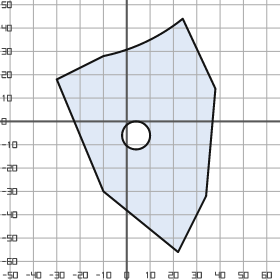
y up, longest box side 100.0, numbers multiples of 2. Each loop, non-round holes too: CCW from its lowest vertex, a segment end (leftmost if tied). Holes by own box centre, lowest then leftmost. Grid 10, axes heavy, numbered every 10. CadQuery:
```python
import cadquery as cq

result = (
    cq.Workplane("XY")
    .moveTo(22.0, -56.0)
    .lineTo(34.0, -32.0)
    .lineTo(38.0, 14.0)
    .lineTo(24.0, 44.0)
    .threePointArc((8.0, 34.0), (-10.0, 28.0))
    .lineTo(-30.0, 18.0)
    .lineTo(-10.0, -30.0)
    .close()
    .moveTo(4.0, -6.0)
    .circle(6.0)
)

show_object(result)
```